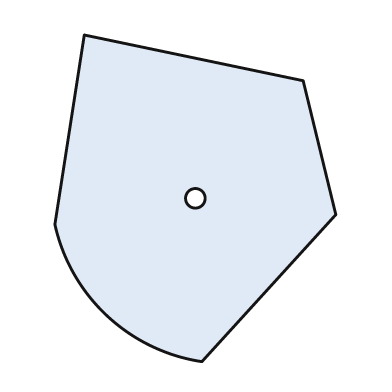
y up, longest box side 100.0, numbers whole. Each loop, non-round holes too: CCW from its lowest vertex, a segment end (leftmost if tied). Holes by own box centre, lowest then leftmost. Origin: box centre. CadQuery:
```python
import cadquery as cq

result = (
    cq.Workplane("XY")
    .moveTo(2.0, -50.0)
    .lineTo(43.0, -5.0)
    .lineTo(33.0, 36.0)
    .lineTo(-34.0, 50.0)
    .lineTo(-43.0, -8.0)
    .threePointArc((-27.0, -36.0), (2.0, -50.0))
    .close()
    .moveTo(0.0, 0.0)
    .circle(3.0)
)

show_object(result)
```